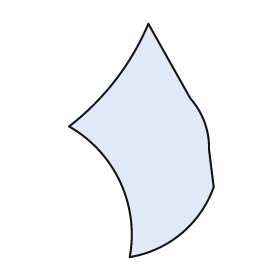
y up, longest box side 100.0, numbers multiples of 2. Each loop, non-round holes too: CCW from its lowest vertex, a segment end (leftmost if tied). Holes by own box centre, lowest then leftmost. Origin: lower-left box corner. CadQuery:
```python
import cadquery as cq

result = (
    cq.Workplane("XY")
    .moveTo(26.0, 0.0)
    .threePointArc((48.0, 10.0), (62.0, 30.0))
    .lineTo(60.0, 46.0)
    .threePointArc((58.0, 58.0), (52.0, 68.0))
    .lineTo(34.0, 100.0)
    .threePointArc((20.0, 76.0), (0.0, 56.0))
    .threePointArc((22.0, 32.0), (26.0, 0.0))
    .close()
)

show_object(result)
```